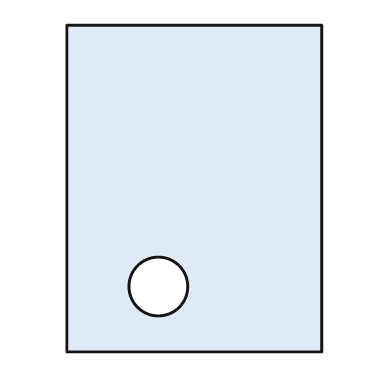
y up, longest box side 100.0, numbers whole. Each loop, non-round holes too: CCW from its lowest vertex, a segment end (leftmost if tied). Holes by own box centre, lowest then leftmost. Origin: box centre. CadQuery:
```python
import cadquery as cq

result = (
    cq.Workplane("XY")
    .moveTo(-39.0, -50.0)
    .lineTo(39.0, -50.0)
    .lineTo(39.0, 50.0)
    .lineTo(-39.0, 50.0)
    .close()
    .moveTo(-11.0, -30.0)
    .circle(9.0)
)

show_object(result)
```